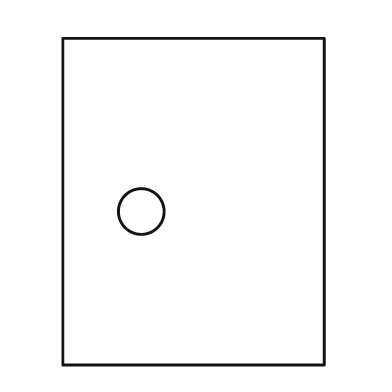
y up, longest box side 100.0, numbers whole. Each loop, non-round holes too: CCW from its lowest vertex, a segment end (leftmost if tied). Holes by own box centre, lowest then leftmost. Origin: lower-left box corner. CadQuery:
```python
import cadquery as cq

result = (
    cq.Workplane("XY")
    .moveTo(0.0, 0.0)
    .lineTo(80.0, 0.0)
    .lineTo(80.0, 100.0)
    .lineTo(0.0, 100.0)
    .close()
    .moveTo(24.0, 47.0)
    .circle(7.0)
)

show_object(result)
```